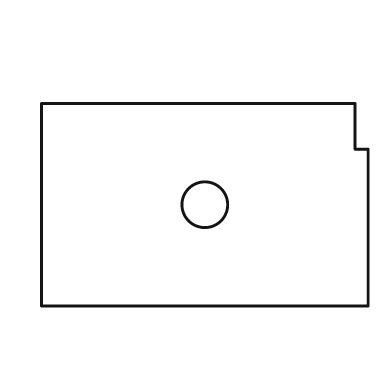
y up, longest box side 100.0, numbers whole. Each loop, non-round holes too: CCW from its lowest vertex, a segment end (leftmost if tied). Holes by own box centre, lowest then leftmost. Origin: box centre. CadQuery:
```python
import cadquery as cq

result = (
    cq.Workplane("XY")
    .moveTo(-50.0, -31.0)
    .lineTo(50.0, -31.0)
    .lineTo(50.0, 17.0)
    .lineTo(46.0, 17.0)
    .lineTo(46.0, 31.0)
    .lineTo(-50.0, 31.0)
    .close()
    .moveTo(0.0, 0.0)
    .circle(7.0)
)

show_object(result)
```